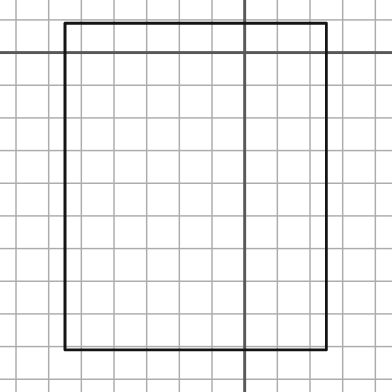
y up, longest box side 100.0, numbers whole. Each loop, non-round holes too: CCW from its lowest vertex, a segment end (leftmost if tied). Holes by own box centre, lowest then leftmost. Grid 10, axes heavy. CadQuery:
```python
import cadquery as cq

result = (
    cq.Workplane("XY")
    .moveTo(-55.0, -91.0)
    .lineTo(25.0, -91.0)
    .lineTo(25.0, 9.0)
    .lineTo(-55.0, 9.0)
    .close()
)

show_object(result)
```